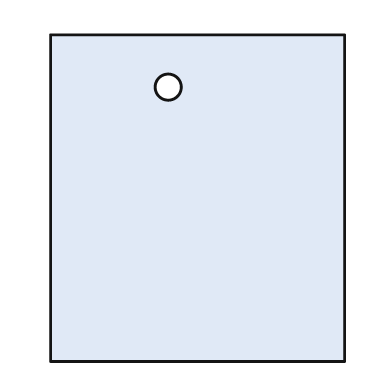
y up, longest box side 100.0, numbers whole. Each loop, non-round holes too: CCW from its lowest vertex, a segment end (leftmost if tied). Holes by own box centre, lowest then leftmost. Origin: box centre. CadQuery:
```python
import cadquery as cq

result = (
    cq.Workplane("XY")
    .moveTo(-45.0, -50.0)
    .lineTo(45.0, -50.0)
    .lineTo(45.0, 50.0)
    .lineTo(-45.0, 50.0)
    .close()
    .moveTo(-9.0, 34.0)
    .circle(4.0)
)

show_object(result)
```